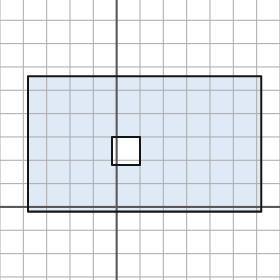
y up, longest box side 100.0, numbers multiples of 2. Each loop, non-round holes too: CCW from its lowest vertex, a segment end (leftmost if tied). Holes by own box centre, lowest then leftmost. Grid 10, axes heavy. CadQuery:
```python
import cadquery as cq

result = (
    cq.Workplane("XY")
    .moveTo(-38.0, -2.0)
    .lineTo(62.0, -2.0)
    .lineTo(62.0, 56.0)
    .lineTo(-38.0, 56.0)
    .close()
    .moveTo(-2.0, 18.0)
    .lineTo(10.0, 18.0)
    .lineTo(10.0, 30.0)
    .lineTo(-2.0, 30.0)
    .close()
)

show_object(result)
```